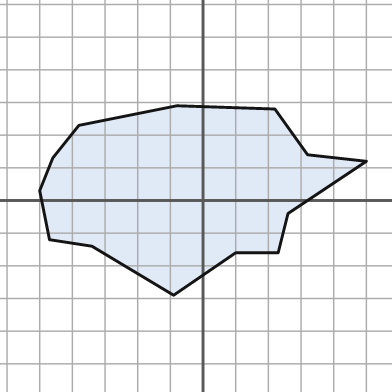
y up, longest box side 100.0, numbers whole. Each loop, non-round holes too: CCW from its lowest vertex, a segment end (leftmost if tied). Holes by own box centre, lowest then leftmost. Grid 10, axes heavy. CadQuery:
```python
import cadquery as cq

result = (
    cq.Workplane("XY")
    .moveTo(-9.0, -29.0)
    .lineTo(10.0, -16.0)
    .lineTo(23.0, -16.0)
    .lineTo(26.0, -4.0)
    .lineTo(50.0, 12.0)
    .lineTo(32.0, 14.0)
    .lineTo(22.0, 28.0)
    .lineTo(-8.0, 29.0)
    .lineTo(-38.0, 23.0)
    .lineTo(-46.0, 13.0)
    .lineTo(-50.0, 3.0)
    .lineTo(-47.0, -12.0)
    .lineTo(-34.0, -14.0)
    .close()
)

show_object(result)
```